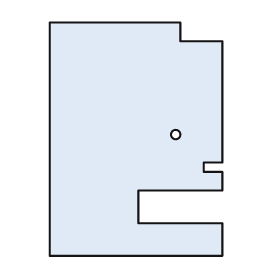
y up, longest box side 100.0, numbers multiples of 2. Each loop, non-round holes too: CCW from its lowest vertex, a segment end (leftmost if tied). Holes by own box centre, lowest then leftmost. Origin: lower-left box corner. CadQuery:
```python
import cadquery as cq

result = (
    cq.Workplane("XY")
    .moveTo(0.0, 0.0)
    .lineTo(74.0, 0.0)
    .lineTo(74.0, 14.0)
    .lineTo(38.0, 14.0)
    .lineTo(38.0, 28.0)
    .lineTo(74.0, 28.0)
    .lineTo(74.0, 36.0)
    .lineTo(66.0, 36.0)
    .lineTo(66.0, 40.0)
    .lineTo(74.0, 40.0)
    .lineTo(74.0, 92.0)
    .lineTo(56.0, 92.0)
    .lineTo(56.0, 100.0)
    .lineTo(0.0, 100.0)
    .close()
    .moveTo(54.0, 52.0)
    .circle(2.0)
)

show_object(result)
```